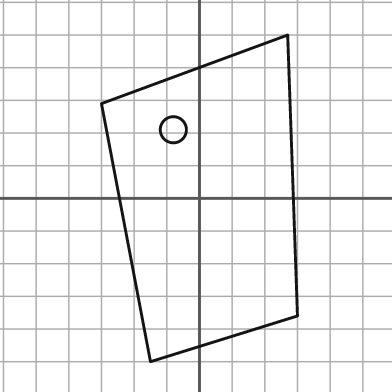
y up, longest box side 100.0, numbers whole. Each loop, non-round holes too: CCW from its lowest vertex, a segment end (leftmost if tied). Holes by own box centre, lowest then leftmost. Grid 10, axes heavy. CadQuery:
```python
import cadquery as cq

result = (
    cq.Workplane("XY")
    .moveTo(-15.0, -50.0)
    .lineTo(30.0, -36.0)
    .lineTo(27.0, 50.0)
    .lineTo(-30.0, 29.0)
    .close()
    .moveTo(-8.0, 21.0)
    .circle(4.0)
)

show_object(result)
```